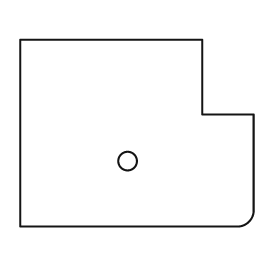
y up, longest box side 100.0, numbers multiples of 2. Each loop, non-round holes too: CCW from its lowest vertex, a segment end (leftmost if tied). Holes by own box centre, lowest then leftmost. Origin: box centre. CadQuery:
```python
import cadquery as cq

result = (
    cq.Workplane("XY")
    .moveTo(-50.0, -40.0)
    .lineTo(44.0, -40.0)
    .threePointArc((48.0, -38.0), (50.0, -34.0))
    .lineTo(50.0, 8.0)
    .lineTo(28.0, 8.0)
    .lineTo(28.0, 40.0)
    .lineTo(-50.0, 40.0)
    .close()
    .moveTo(-4.0, -12.0)
    .circle(4.0)
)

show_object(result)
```